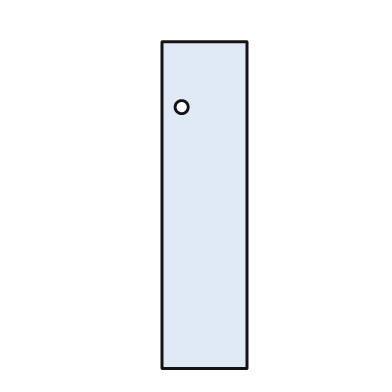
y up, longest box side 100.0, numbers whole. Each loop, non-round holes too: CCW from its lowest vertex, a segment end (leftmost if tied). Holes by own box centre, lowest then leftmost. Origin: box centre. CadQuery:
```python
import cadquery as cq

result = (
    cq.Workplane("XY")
    .moveTo(-13.0, -50.0)
    .lineTo(13.0, -50.0)
    .lineTo(13.0, 50.0)
    .lineTo(-13.0, 50.0)
    .close()
    .moveTo(-7.0, 30.0)
    .circle(2.0)
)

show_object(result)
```